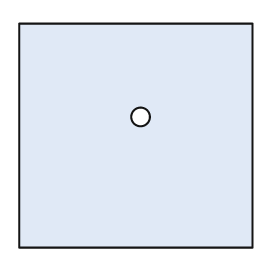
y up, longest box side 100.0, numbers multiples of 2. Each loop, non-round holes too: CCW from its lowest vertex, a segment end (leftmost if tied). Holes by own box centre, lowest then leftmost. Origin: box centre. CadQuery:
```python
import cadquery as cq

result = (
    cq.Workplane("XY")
    .moveTo(-50.0, -48.0)
    .lineTo(50.0, -48.0)
    .lineTo(50.0, 48.0)
    .lineTo(-50.0, 48.0)
    .close()
    .moveTo(2.0, 8.0)
    .circle(4.0)
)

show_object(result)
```